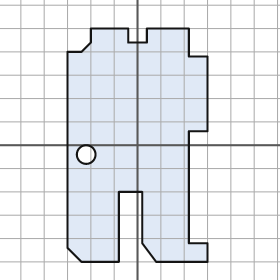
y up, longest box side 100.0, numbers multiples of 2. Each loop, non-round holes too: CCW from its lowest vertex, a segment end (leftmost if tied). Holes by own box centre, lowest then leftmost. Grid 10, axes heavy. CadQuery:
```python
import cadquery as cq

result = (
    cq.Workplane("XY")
    .moveTo(-24.0, -50.0)
    .lineTo(-8.0, -50.0)
    .lineTo(-8.0, -20.0)
    .lineTo(2.0, -20.0)
    .lineTo(2.0, -42.0)
    .lineTo(8.0, -50.0)
    .lineTo(30.0, -50.0)
    .lineTo(30.0, -42.0)
    .lineTo(22.0, -42.0)
    .lineTo(22.0, 6.0)
    .lineTo(30.0, 6.0)
    .lineTo(30.0, 38.0)
    .lineTo(22.0, 38.0)
    .lineTo(22.0, 50.0)
    .lineTo(4.0, 50.0)
    .lineTo(4.0, 44.0)
    .lineTo(-4.0, 44.0)
    .lineTo(-4.0, 50.0)
    .lineTo(-20.0, 50.0)
    .lineTo(-20.0, 44.0)
    .lineTo(-24.0, 40.0)
    .lineTo(-30.0, 40.0)
    .lineTo(-30.0, -44.0)
    .close()
    .moveTo(-22.0, -4.0)
    .circle(4.0)
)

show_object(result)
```